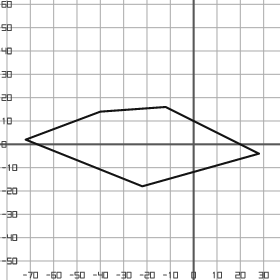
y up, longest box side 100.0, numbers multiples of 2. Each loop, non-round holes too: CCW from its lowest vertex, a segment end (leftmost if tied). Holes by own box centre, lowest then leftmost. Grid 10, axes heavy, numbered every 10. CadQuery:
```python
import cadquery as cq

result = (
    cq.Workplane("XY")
    .moveTo(-22.0, -18.0)
    .lineTo(28.0, -4.0)
    .lineTo(-12.0, 16.0)
    .lineTo(-40.0, 14.0)
    .lineTo(-72.0, 2.0)
    .close()
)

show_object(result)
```